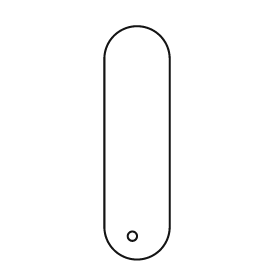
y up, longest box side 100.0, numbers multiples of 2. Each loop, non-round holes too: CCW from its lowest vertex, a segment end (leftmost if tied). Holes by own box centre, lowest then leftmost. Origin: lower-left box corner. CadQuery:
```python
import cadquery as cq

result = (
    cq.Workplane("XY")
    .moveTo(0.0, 14.0)
    .threePointArc((14.0, 0.0), (28.0, 14.0))
    .lineTo(28.0, 86.0)
    .threePointArc((14.0, 100.0), (0.0, 86.0))
    .close()
    .moveTo(12.0, 10.0)
    .circle(2.0)
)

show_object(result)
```